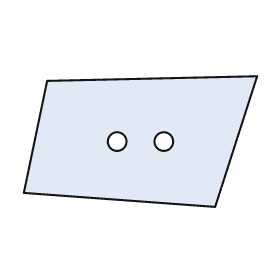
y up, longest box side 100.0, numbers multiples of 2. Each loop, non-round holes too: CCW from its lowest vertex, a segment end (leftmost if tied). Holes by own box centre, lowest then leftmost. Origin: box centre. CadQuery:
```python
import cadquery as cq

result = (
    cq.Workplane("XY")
    .moveTo(32.0, -28.0)
    .lineTo(50.0, 28.0)
    .lineTo(-40.0, 26.0)
    .lineTo(-50.0, -22.0)
    .close()
    .moveTo(-10.0, 0.0)
    .circle(4.0)
    .moveTo(10.0, 0.0)
    .circle(4.0)
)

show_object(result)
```